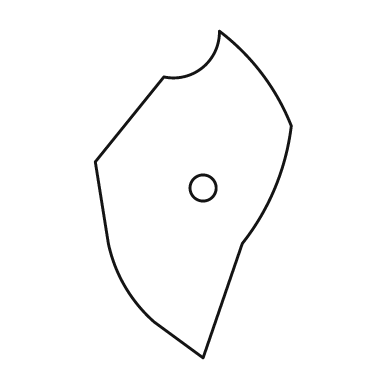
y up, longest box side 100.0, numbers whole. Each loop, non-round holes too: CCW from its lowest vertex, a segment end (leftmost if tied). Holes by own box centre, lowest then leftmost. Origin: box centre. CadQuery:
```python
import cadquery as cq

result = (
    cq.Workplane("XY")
    .moveTo(3.0, -50.0)
    .lineTo(15.0, -15.0)
    .threePointArc((25.0, 2.0), (30.0, 21.0))
    .threePointArc((21.0, 37.0), (8.0, 50.0))
    .threePointArc((3.0, 39.0), (-9.0, 36.0))
    .lineTo(-30.0, 10.0)
    .lineTo(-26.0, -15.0)
    .threePointArc((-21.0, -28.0), (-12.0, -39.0))
    .close()
    .moveTo(3.0, 2.0)
    .circle(4.0)
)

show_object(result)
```